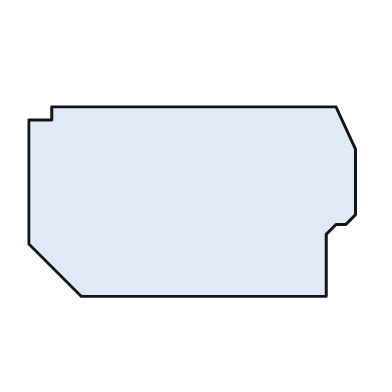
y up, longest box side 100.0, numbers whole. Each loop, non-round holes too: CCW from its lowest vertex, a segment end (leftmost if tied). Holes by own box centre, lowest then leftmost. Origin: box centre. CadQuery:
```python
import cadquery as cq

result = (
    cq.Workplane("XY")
    .moveTo(-34.0, -29.0)
    .lineTo(41.0, -29.0)
    .lineTo(41.0, -10.0)
    .lineTo(44.0, -7.0)
    .lineTo(47.0, -7.0)
    .lineTo(50.0, -4.0)
    .lineTo(50.0, 16.0)
    .lineTo(44.0, 29.0)
    .lineTo(-43.0, 29.0)
    .lineTo(-43.0, 25.0)
    .lineTo(-50.0, 25.0)
    .lineTo(-50.0, -13.0)
    .close()
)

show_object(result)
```